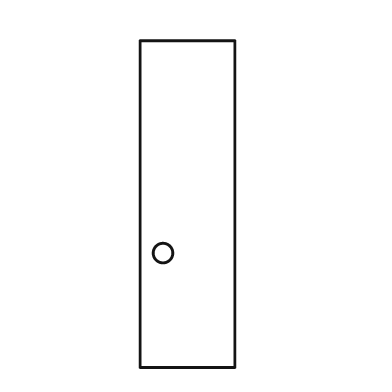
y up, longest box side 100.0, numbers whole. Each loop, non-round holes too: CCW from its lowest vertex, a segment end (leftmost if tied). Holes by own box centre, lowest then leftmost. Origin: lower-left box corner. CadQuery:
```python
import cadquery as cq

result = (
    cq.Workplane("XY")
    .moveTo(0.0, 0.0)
    .lineTo(29.0, 0.0)
    .lineTo(29.0, 100.0)
    .lineTo(0.0, 100.0)
    .close()
    .moveTo(7.0, 35.0)
    .circle(3.0)
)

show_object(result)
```